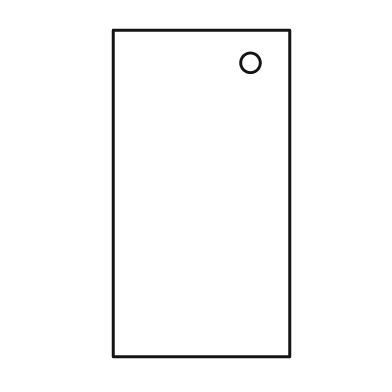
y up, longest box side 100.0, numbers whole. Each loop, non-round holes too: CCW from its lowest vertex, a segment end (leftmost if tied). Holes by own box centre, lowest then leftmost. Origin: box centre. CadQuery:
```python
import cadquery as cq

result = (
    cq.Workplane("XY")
    .moveTo(-27.0, -50.0)
    .lineTo(27.0, -50.0)
    .lineTo(27.0, 50.0)
    .lineTo(-27.0, 50.0)
    .close()
    .moveTo(15.0, 40.0)
    .circle(3.0)
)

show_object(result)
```